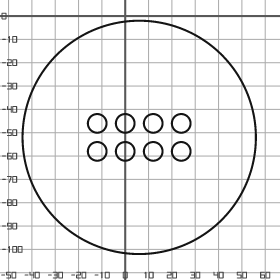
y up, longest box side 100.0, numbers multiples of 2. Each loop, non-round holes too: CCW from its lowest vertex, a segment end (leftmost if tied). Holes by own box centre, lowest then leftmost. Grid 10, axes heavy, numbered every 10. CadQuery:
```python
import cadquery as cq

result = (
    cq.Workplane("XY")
    .moveTo(6.0, -52.0)
    .circle(50.0)
    .moveTo(-12.0, -58.0)
    .circle(4.0)
    .moveTo(0.0, -58.0)
    .circle(4.0)
    .moveTo(12.0, -58.0)
    .circle(4.0)
    .moveTo(24.0, -58.0)
    .circle(4.0)
    .moveTo(-12.0, -46.0)
    .circle(4.0)
    .moveTo(0.0, -46.0)
    .circle(4.0)
    .moveTo(12.0, -46.0)
    .circle(4.0)
    .moveTo(24.0, -46.0)
    .circle(4.0)
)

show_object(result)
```